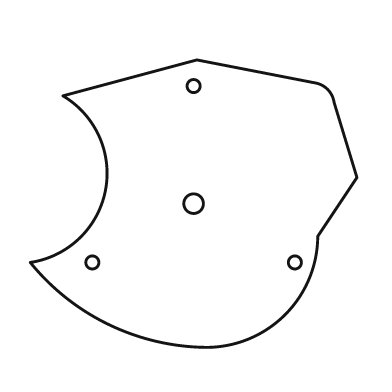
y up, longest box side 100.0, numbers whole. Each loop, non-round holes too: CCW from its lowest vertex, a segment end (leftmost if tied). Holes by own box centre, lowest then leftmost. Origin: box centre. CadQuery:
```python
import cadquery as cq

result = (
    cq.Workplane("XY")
    .moveTo(4.0, -44.0)
    .threePointArc((28.0, -34.0), (38.0, -10.0))
    .lineTo(50.0, 8.0)
    .lineTo(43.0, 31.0)
    .threePointArc((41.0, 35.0), (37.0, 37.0))
    .lineTo(1.0, 44.0)
    .lineTo(-40.0, 33.0)
    .threePointArc((-27.0, 4.0), (-50.0, -18.0))
    .threePointArc((-26.0, -37.0), (4.0, -44.0))
    .close()
    .moveTo(-31.0, -18.0)
    .circle(2.0)
    .moveTo(31.0, -18.0)
    .circle(2.0)
    .moveTo(0.0, 0.0)
    .circle(3.0)
    .moveTo(0.0, 36.0)
    .circle(2.0)
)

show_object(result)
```